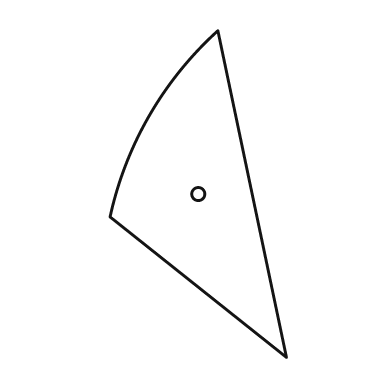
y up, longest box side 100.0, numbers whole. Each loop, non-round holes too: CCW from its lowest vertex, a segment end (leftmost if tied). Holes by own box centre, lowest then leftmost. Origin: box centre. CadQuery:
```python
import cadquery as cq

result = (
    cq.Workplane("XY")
    .moveTo(27.0, -50.0)
    .lineTo(6.0, 50.0)
    .threePointArc((-15.0, 24.0), (-27.0, -7.0))
    .close()
    .moveTo(0.0, 0.0)
    .circle(2.0)
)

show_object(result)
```